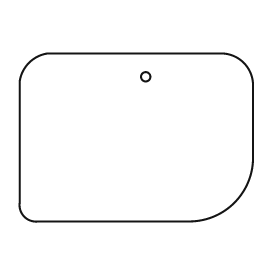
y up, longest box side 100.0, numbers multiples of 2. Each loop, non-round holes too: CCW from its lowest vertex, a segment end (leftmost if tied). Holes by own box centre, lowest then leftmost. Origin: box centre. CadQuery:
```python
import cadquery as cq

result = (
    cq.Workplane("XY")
    .moveTo(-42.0, -36.0)
    .lineTo(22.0, -36.0)
    .threePointArc((42.0, -28.0), (50.0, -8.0))
    .lineTo(50.0, 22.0)
    .threePointArc((46.0, 32.0), (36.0, 36.0))
    .lineTo(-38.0, 36.0)
    .threePointArc((-46.0, 32.0), (-50.0, 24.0))
    .lineTo(-50.0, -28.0)
    .threePointArc((-48.0, -34.0), (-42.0, -36.0))
    .close()
    .moveTo(4.0, 26.0)
    .circle(2.0)
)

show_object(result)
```